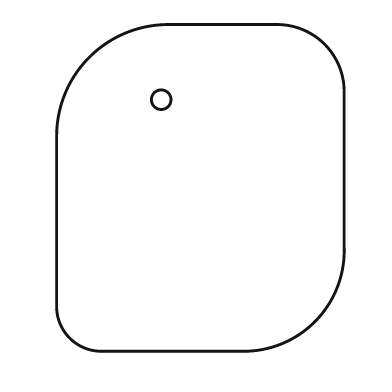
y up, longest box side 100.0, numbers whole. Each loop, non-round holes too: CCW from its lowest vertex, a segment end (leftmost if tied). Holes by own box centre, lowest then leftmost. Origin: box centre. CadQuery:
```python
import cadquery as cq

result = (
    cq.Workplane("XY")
    .moveTo(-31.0, -50.0)
    .lineTo(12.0, -50.0)
    .threePointArc((35.0, -41.0), (44.0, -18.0))
    .lineTo(44.0, 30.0)
    .threePointArc((38.0, 44.0), (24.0, 50.0))
    .lineTo(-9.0, 50.0)
    .threePointArc((-34.0, 40.0), (-44.0, 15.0))
    .lineTo(-44.0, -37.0)
    .threePointArc((-40.0, -46.0), (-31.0, -50.0))
    .close()
    .moveTo(-12.0, 27.0)
    .circle(3.0)
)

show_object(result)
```